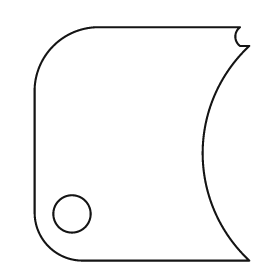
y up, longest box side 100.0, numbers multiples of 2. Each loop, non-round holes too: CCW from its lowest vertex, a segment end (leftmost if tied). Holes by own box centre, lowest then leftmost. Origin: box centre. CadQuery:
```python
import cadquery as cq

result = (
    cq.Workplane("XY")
    .moveTo(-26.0, -50.0)
    .lineTo(46.0, -50.0)
    .threePointArc((26.0, -4.0), (46.0, 42.0))
    .lineTo(42.0, 42.0)
    .threePointArc((40.0, 46.0), (42.0, 50.0))
    .lineTo(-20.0, 50.0)
    .threePointArc((-38.0, 42.0), (-46.0, 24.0))
    .lineTo(-46.0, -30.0)
    .threePointArc((-40.0, -44.0), (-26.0, -50.0))
    .close()
    .moveTo(-30.0, -30.0)
    .circle(8.0)
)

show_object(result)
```